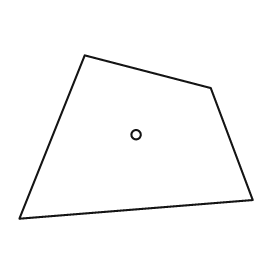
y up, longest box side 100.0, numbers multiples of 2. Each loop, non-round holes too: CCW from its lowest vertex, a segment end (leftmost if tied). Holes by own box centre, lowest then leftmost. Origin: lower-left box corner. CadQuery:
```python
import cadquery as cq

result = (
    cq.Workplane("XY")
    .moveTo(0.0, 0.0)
    .lineTo(100.0, 8.0)
    .lineTo(82.0, 56.0)
    .lineTo(28.0, 70.0)
    .close()
    .moveTo(50.0, 36.0)
    .circle(2.0)
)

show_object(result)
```